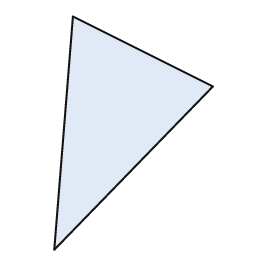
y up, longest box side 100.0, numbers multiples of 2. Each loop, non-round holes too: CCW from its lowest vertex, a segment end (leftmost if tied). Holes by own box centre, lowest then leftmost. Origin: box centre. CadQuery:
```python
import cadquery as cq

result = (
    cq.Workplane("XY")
    .moveTo(-34.0, -50.0)
    .lineTo(34.0, 20.0)
    .lineTo(-26.0, 50.0)
    .close()
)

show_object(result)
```